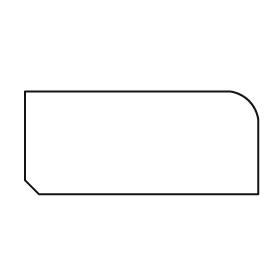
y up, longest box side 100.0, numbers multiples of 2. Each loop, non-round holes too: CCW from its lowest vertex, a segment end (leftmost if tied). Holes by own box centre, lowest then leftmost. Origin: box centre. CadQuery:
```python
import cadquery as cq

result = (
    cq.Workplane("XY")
    .moveTo(-44.0, -22.0)
    .lineTo(50.0, -22.0)
    .lineTo(50.0, 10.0)
    .threePointArc((46.0, 18.0), (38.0, 22.0))
    .lineTo(-50.0, 22.0)
    .lineTo(-50.0, -16.0)
    .close()
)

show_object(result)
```